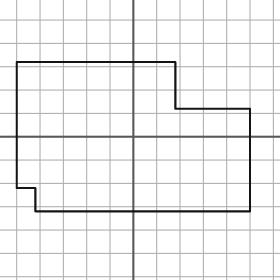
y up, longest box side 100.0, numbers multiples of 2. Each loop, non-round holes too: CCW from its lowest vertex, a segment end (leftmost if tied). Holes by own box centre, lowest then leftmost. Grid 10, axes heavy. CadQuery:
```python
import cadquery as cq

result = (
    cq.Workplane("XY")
    .moveTo(-42.0, -32.0)
    .lineTo(50.0, -32.0)
    .lineTo(50.0, 12.0)
    .lineTo(18.0, 12.0)
    .lineTo(18.0, 32.0)
    .lineTo(-50.0, 32.0)
    .lineTo(-50.0, -22.0)
    .lineTo(-42.0, -22.0)
    .close()
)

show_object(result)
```